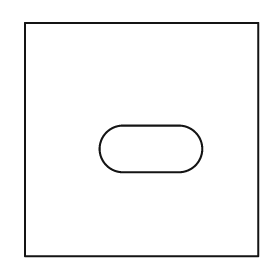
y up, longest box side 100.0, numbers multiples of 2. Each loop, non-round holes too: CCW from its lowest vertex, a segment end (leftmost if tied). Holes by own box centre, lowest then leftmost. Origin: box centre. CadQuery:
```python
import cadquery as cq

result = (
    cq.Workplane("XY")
    .moveTo(-50.0, -50.0)
    .lineTo(50.0, -50.0)
    .lineTo(50.0, 50.0)
    .lineTo(-50.0, 50.0)
    .close()
    .moveTo(-8.0, -14.0)
    .lineTo(16.0, -14.0)
    .threePointArc((26.0, -4.0), (16.0, 6.0))
    .lineTo(-8.0, 6.0)
    .threePointArc((-18.0, -4.0), (-8.0, -14.0))
    .close()
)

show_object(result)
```